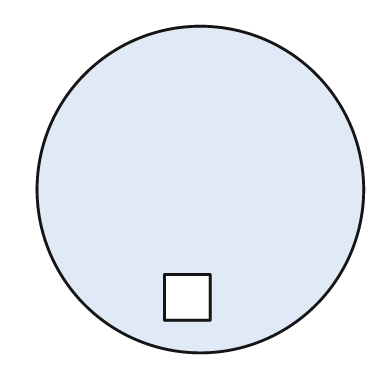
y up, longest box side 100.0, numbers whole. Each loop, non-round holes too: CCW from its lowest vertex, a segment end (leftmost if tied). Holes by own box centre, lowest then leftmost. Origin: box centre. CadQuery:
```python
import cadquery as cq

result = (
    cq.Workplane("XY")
    .moveTo(0.0, 0.0)
    .circle(50.0)
    .moveTo(-11.0, -40.0)
    .lineTo(3.0, -40.0)
    .lineTo(3.0, -26.0)
    .lineTo(-11.0, -26.0)
    .close()
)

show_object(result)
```